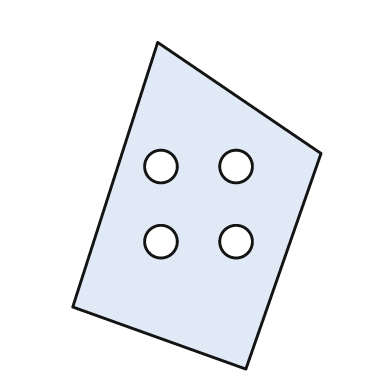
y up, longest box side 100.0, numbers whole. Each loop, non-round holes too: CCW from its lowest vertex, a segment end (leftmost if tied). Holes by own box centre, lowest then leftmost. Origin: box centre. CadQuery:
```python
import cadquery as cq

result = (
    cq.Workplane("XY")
    .moveTo(15.0, -50.0)
    .lineTo(38.0, 16.0)
    .lineTo(-12.0, 50.0)
    .lineTo(-38.0, -31.0)
    .close()
    .moveTo(-11.0, -11.0)
    .circle(5.0)
    .moveTo(12.0, -11.0)
    .circle(5.0)
    .moveTo(-11.0, 12.0)
    .circle(5.0)
    .moveTo(12.0, 12.0)
    .circle(5.0)
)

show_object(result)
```